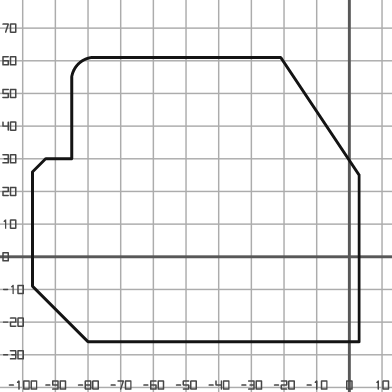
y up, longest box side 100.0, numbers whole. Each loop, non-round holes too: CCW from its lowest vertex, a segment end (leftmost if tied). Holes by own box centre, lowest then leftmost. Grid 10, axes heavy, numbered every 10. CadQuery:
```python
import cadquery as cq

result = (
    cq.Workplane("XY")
    .moveTo(-80.0, -26.0)
    .lineTo(3.0, -26.0)
    .lineTo(3.0, 25.0)
    .lineTo(-21.0, 61.0)
    .lineTo(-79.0, 61.0)
    .threePointArc((-83.0, 59.0), (-85.0, 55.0))
    .lineTo(-85.0, 30.0)
    .lineTo(-93.0, 30.0)
    .lineTo(-97.0, 26.0)
    .lineTo(-97.0, -9.0)
    .close()
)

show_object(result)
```